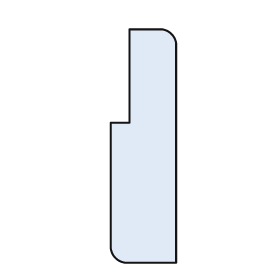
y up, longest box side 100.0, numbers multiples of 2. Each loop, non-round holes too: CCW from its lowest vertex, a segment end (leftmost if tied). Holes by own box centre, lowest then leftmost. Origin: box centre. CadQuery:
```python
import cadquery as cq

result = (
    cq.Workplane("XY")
    .moveTo(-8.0, -50.0)
    .lineTo(14.0, -50.0)
    .lineTo(14.0, 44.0)
    .threePointArc((12.0, 48.0), (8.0, 50.0))
    .lineTo(-6.0, 50.0)
    .lineTo(-6.0, 10.0)
    .lineTo(-14.0, 10.0)
    .lineTo(-14.0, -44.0)
    .threePointArc((-12.0, -48.0), (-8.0, -50.0))
    .close()
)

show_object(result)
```